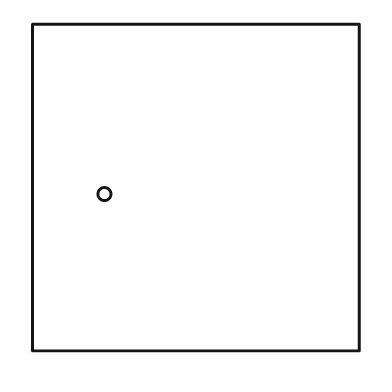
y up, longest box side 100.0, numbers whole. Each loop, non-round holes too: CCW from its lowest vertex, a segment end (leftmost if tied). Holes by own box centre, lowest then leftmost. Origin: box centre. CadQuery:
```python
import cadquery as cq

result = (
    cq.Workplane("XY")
    .moveTo(-50.0, -50.0)
    .lineTo(50.0, -50.0)
    .lineTo(50.0, 50.0)
    .lineTo(-50.0, 50.0)
    .close()
    .moveTo(-28.0, -2.0)
    .circle(2.0)
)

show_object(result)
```